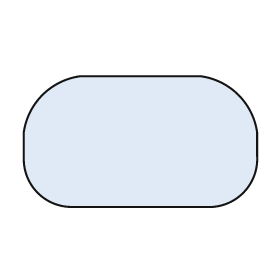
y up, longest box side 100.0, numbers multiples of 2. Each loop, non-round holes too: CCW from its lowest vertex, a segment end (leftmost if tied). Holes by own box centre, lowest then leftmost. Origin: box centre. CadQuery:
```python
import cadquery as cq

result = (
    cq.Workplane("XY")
    .moveTo(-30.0, -28.0)
    .lineTo(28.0, -28.0)
    .threePointArc((44.0, -22.0), (50.0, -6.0))
    .lineTo(50.0, 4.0)
    .threePointArc((42.0, 20.0), (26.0, 28.0))
    .lineTo(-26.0, 28.0)
    .threePointArc((-42.0, 20.0), (-50.0, 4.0))
    .lineTo(-50.0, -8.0)
    .threePointArc((-44.0, -22.0), (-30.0, -28.0))
    .close()
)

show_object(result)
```